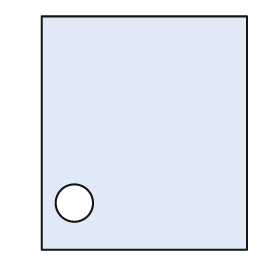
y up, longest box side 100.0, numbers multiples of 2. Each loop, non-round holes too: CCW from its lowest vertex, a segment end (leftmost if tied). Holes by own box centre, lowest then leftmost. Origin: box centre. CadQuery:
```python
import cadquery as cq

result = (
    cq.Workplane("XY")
    .moveTo(-44.0, -50.0)
    .lineTo(44.0, -50.0)
    .lineTo(44.0, 50.0)
    .lineTo(-44.0, 50.0)
    .close()
    .moveTo(-30.0, -30.0)
    .circle(8.0)
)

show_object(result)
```